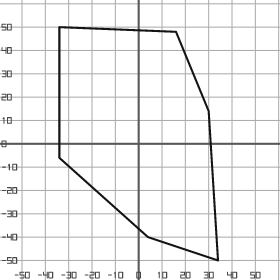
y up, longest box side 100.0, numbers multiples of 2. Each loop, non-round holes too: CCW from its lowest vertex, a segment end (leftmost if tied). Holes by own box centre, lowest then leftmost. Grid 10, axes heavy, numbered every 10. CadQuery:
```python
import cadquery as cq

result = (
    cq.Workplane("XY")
    .moveTo(34.0, -50.0)
    .lineTo(30.0, 14.0)
    .lineTo(16.0, 48.0)
    .lineTo(-34.0, 50.0)
    .lineTo(-34.0, -6.0)
    .lineTo(4.0, -40.0)
    .close()
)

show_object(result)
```